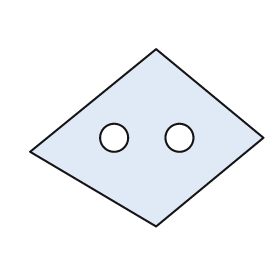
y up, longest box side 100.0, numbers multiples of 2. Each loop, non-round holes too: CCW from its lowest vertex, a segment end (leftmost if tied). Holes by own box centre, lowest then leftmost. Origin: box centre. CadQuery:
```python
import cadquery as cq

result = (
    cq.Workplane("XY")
    .moveTo(4.0, -38.0)
    .lineTo(50.0, 0.0)
    .lineTo(4.0, 38.0)
    .lineTo(-50.0, -6.0)
    .close()
    .moveTo(-14.0, 0.0)
    .circle(6.0)
    .moveTo(14.0, 0.0)
    .circle(6.0)
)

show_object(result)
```